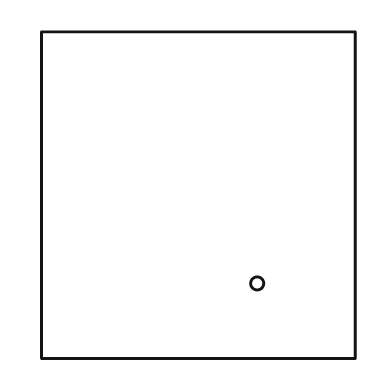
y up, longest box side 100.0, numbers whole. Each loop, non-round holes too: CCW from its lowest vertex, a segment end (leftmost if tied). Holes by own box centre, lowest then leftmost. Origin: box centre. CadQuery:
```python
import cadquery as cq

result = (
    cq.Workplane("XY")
    .moveTo(-48.0, -50.0)
    .lineTo(48.0, -50.0)
    .lineTo(48.0, 50.0)
    .lineTo(-48.0, 50.0)
    .close()
    .moveTo(18.0, -27.0)
    .circle(2.0)
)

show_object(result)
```